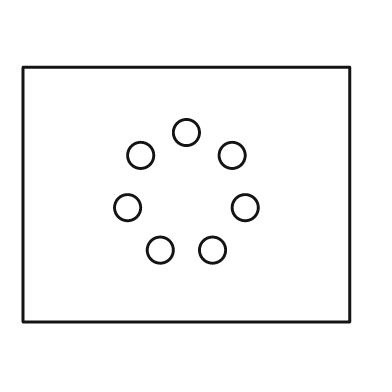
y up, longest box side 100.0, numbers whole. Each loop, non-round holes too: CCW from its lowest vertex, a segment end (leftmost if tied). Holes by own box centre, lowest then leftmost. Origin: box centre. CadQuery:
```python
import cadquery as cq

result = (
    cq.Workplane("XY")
    .moveTo(-50.0, -39.0)
    .lineTo(50.0, -39.0)
    .lineTo(50.0, 39.0)
    .lineTo(-50.0, 39.0)
    .close()
    .moveTo(-8.0, -17.0)
    .circle(4.0)
    .moveTo(8.0, -17.0)
    .circle(4.0)
    .moveTo(-18.0, -4.0)
    .circle(4.0)
    .moveTo(18.0, -4.0)
    .circle(4.0)
    .moveTo(-14.0, 12.0)
    .circle(4.0)
    .moveTo(14.0, 12.0)
    .circle(4.0)
    .moveTo(0.0, 19.0)
    .circle(4.0)
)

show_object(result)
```